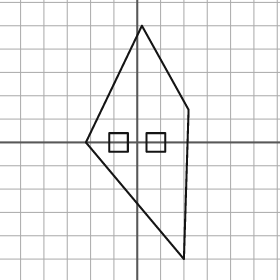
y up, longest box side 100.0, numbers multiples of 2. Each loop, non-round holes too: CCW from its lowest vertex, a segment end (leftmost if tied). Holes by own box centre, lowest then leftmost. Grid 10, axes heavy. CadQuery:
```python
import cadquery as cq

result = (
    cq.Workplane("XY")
    .moveTo(20.0, -50.0)
    .lineTo(22.0, 14.0)
    .lineTo(2.0, 50.0)
    .lineTo(-22.0, 0.0)
    .close()
    .moveTo(-12.0, -4.0)
    .lineTo(-4.0, -4.0)
    .lineTo(-4.0, 4.0)
    .lineTo(-12.0, 4.0)
    .close()
    .moveTo(4.0, -4.0)
    .lineTo(12.0, -4.0)
    .lineTo(12.0, 4.0)
    .lineTo(4.0, 4.0)
    .close()
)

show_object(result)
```